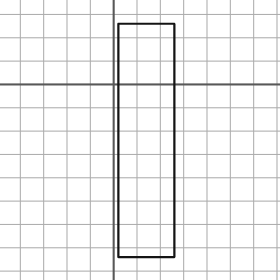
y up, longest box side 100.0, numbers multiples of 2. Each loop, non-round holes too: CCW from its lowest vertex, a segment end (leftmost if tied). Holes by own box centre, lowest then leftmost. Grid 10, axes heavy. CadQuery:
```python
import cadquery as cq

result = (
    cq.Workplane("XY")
    .moveTo(2.0, -74.0)
    .lineTo(26.0, -74.0)
    .lineTo(26.0, 26.0)
    .lineTo(2.0, 26.0)
    .close()
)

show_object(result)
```